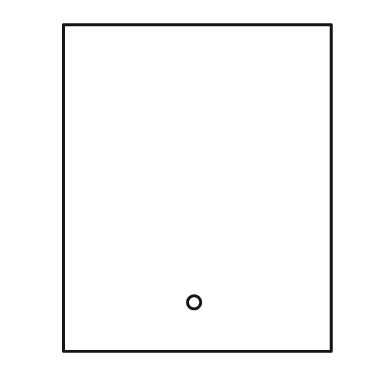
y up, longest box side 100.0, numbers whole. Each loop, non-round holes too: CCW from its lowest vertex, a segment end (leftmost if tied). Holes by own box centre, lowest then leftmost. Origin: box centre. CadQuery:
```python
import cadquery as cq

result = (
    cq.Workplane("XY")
    .moveTo(-41.0, -50.0)
    .lineTo(41.0, -50.0)
    .lineTo(41.0, 50.0)
    .lineTo(-41.0, 50.0)
    .close()
    .moveTo(-1.0, -35.0)
    .circle(2.0)
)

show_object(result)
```